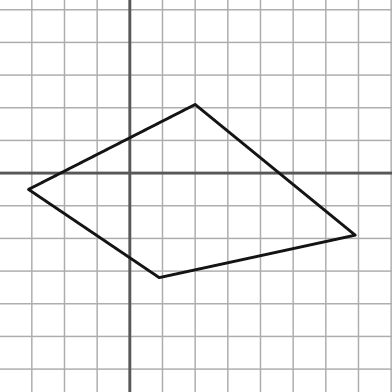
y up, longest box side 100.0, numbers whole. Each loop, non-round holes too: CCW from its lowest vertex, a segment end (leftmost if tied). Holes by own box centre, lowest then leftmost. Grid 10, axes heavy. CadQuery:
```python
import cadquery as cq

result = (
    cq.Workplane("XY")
    .moveTo(9.0, -32.0)
    .lineTo(69.0, -19.0)
    .lineTo(20.0, 21.0)
    .lineTo(-31.0, -5.0)
    .close()
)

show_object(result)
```